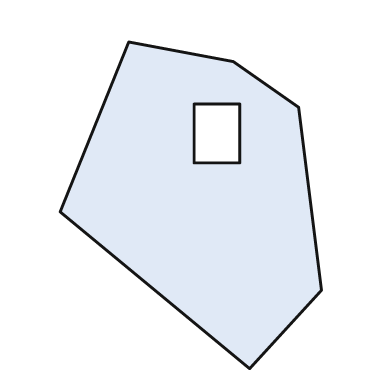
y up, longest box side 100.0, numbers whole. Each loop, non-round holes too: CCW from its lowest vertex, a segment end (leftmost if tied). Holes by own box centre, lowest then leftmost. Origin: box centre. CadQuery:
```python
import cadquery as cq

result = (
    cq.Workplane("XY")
    .moveTo(18.0, -50.0)
    .lineTo(40.0, -26.0)
    .lineTo(33.0, 30.0)
    .lineTo(13.0, 44.0)
    .lineTo(-19.0, 50.0)
    .lineTo(-40.0, -2.0)
    .close()
    .moveTo(1.0, 13.0)
    .lineTo(15.0, 13.0)
    .lineTo(15.0, 31.0)
    .lineTo(1.0, 31.0)
    .close()
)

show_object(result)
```